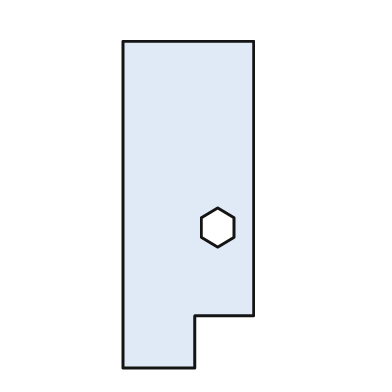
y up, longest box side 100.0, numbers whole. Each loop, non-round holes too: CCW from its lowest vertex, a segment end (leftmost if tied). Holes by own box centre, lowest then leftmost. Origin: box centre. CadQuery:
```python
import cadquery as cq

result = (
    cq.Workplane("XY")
    .moveTo(-20.0, -50.0)
    .lineTo(2.0, -50.0)
    .lineTo(2.0, -34.0)
    .lineTo(20.0, -34.0)
    .lineTo(20.0, 50.0)
    .lineTo(-20.0, 50.0)
    .close()
    .moveTo(9.0, -13.0)
    .lineTo(14.0, -10.0)
    .lineTo(14.0, -4.0)
    .lineTo(9.0, -1.0)
    .lineTo(4.0, -4.0)
    .lineTo(4.0, -10.0)
    .close()
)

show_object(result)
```